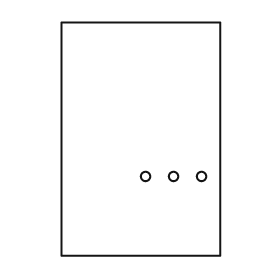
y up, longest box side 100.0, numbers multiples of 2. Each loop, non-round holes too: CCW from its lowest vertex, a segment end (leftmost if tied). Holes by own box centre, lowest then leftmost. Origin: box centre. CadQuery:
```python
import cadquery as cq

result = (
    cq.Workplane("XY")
    .moveTo(-34.0, -50.0)
    .lineTo(34.0, -50.0)
    .lineTo(34.0, 50.0)
    .lineTo(-34.0, 50.0)
    .close()
    .moveTo(2.0, -16.0)
    .circle(2.0)
    .moveTo(14.0, -16.0)
    .circle(2.0)
    .moveTo(26.0, -16.0)
    .circle(2.0)
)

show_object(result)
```